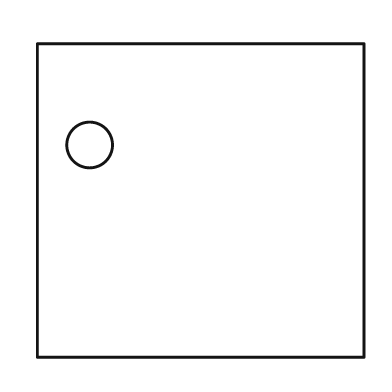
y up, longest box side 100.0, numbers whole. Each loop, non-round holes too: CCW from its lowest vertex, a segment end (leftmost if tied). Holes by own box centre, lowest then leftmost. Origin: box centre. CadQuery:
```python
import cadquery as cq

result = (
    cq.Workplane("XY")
    .moveTo(-50.0, -48.0)
    .lineTo(50.0, -48.0)
    .lineTo(50.0, 48.0)
    .lineTo(-50.0, 48.0)
    .close()
    .moveTo(-34.0, 17.0)
    .circle(7.0)
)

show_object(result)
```